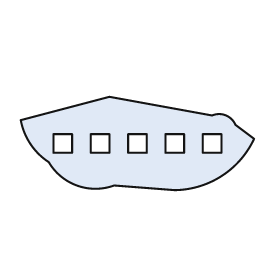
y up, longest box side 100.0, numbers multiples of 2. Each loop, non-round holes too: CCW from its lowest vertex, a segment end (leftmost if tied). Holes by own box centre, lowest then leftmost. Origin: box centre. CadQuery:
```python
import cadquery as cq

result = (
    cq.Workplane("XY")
    .moveTo(16.0, -20.0)
    .threePointArc((36.0, -14.0), (50.0, 2.0))
    .lineTo(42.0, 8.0)
    .threePointArc((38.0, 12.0), (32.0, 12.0))
    .lineTo(-12.0, 20.0)
    .lineTo(-50.0, 10.0)
    .threePointArc((-46.0, 0.0), (-38.0, -8.0))
    .threePointArc((-26.0, -18.0), (-10.0, -18.0))
    .close()
    .moveTo(-36.0, -4.0)
    .lineTo(-28.0, -4.0)
    .lineTo(-28.0, 4.0)
    .lineTo(-36.0, 4.0)
    .close()
    .moveTo(-20.0, -4.0)
    .lineTo(-12.0, -4.0)
    .lineTo(-12.0, 4.0)
    .lineTo(-20.0, 4.0)
    .close()
    .moveTo(-4.0, -4.0)
    .lineTo(4.0, -4.0)
    .lineTo(4.0, 4.0)
    .lineTo(-4.0, 4.0)
    .close()
    .moveTo(12.0, -4.0)
    .lineTo(20.0, -4.0)
    .lineTo(20.0, 4.0)
    .lineTo(12.0, 4.0)
    .close()
    .moveTo(28.0, -4.0)
    .lineTo(36.0, -4.0)
    .lineTo(36.0, 4.0)
    .lineTo(28.0, 4.0)
    .close()
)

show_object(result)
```